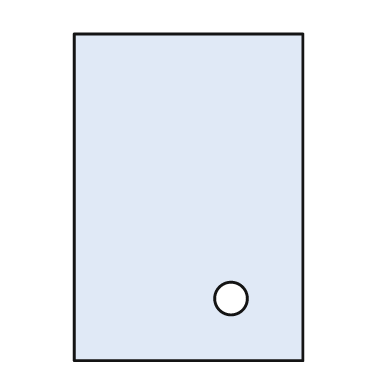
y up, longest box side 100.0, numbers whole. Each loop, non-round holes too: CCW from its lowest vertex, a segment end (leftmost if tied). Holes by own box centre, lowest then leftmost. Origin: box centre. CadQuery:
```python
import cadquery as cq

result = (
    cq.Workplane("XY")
    .moveTo(-35.0, -50.0)
    .lineTo(35.0, -50.0)
    .lineTo(35.0, 50.0)
    .lineTo(-35.0, 50.0)
    .close()
    .moveTo(13.0, -31.0)
    .circle(5.0)
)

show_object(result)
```